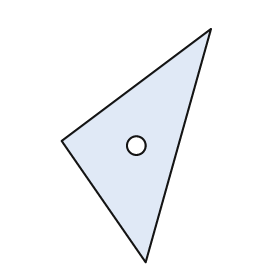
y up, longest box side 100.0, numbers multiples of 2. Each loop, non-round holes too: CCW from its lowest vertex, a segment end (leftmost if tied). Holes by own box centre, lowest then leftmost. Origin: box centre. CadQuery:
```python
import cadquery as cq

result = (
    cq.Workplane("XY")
    .moveTo(4.0, -50.0)
    .lineTo(32.0, 50.0)
    .lineTo(-32.0, 2.0)
    .close()
    .moveTo(0.0, 0.0)
    .circle(4.0)
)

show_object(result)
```